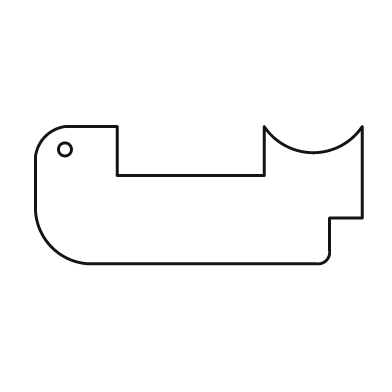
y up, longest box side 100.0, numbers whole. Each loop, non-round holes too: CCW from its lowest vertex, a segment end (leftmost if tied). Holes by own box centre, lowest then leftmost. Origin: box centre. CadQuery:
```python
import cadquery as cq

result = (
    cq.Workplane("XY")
    .moveTo(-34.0, -21.0)
    .lineTo(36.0, -21.0)
    .threePointArc((39.0, -20.0), (40.0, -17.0))
    .lineTo(40.0, -7.0)
    .lineTo(50.0, -7.0)
    .lineTo(50.0, 21.0)
    .threePointArc((35.0, 13.0), (20.0, 21.0))
    .lineTo(20.0, 6.0)
    .lineTo(-25.0, 6.0)
    .lineTo(-25.0, 21.0)
    .lineTo(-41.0, 21.0)
    .threePointArc((-47.0, 18.0), (-50.0, 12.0))
    .lineTo(-50.0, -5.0)
    .threePointArc((-45.0, -16.0), (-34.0, -21.0))
    .close()
    .moveTo(-41.0, 14.0)
    .circle(2.0)
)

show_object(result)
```